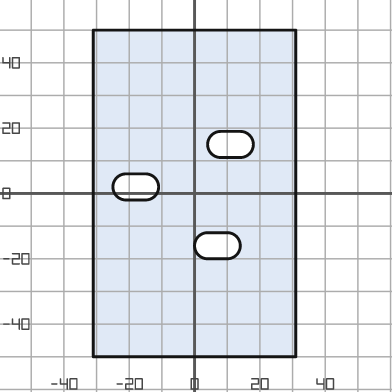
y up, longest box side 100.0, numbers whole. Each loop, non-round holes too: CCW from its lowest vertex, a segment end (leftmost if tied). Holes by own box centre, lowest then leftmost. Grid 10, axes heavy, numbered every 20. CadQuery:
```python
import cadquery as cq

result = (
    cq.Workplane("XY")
    .moveTo(-31.0, -50.0)
    .lineTo(31.0, -50.0)
    .lineTo(31.0, 50.0)
    .lineTo(-31.0, 50.0)
    .close()
    .moveTo(4.0, -20.0)
    .lineTo(10.0, -20.0)
    .threePointArc((14.0, -16.0), (10.0, -12.0))
    .lineTo(4.0, -12.0)
    .threePointArc((0.0, -16.0), (4.0, -20.0))
    .close()
    .moveTo(-21.0, -2.0)
    .lineTo(-15.0, -2.0)
    .threePointArc((-11.0, 2.0), (-15.0, 6.0))
    .lineTo(-21.0, 6.0)
    .threePointArc((-25.0, 2.0), (-21.0, -2.0))
    .close()
    .moveTo(8.0, 11.0)
    .lineTo(14.0, 11.0)
    .threePointArc((18.0, 15.0), (14.0, 19.0))
    .lineTo(8.0, 19.0)
    .threePointArc((4.0, 15.0), (8.0, 11.0))
    .close()
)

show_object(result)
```